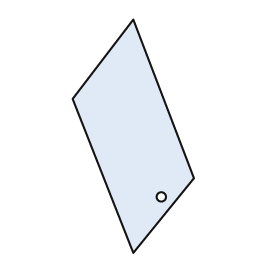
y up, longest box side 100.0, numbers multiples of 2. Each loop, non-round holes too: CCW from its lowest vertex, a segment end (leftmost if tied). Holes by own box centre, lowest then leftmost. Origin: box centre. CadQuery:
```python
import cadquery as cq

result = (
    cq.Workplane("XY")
    .moveTo(0.0, -50.0)
    .lineTo(26.0, -18.0)
    .lineTo(0.0, 50.0)
    .lineTo(-26.0, 16.0)
    .close()
    .moveTo(12.0, -26.0)
    .circle(2.0)
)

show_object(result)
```